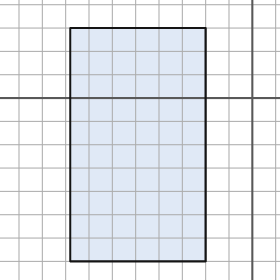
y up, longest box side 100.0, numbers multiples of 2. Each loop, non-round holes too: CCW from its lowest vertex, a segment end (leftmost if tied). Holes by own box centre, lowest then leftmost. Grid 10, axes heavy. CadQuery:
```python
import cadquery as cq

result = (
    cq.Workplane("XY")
    .moveTo(-78.0, -70.0)
    .lineTo(-20.0, -70.0)
    .lineTo(-20.0, 30.0)
    .lineTo(-78.0, 30.0)
    .close()
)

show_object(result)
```